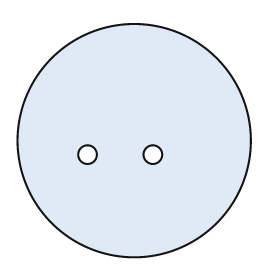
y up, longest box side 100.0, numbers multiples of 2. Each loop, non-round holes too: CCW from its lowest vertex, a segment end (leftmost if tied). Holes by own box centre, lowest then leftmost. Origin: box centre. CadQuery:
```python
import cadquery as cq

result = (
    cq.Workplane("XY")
    .moveTo(0.0, 0.0)
    .circle(50.0)
    .moveTo(-20.0, -6.0)
    .circle(4.0)
    .moveTo(8.0, -6.0)
    .circle(4.0)
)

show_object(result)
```